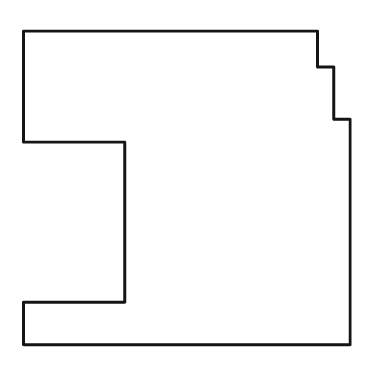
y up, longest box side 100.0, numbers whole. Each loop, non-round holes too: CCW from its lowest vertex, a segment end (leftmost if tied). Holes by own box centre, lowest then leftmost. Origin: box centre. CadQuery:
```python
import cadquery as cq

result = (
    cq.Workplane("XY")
    .moveTo(-50.0, -48.0)
    .lineTo(50.0, -48.0)
    .lineTo(50.0, 21.0)
    .lineTo(45.0, 21.0)
    .lineTo(45.0, 37.0)
    .lineTo(40.0, 37.0)
    .lineTo(40.0, 48.0)
    .lineTo(-50.0, 48.0)
    .lineTo(-50.0, 14.0)
    .lineTo(-19.0, 14.0)
    .lineTo(-19.0, -35.0)
    .lineTo(-50.0, -35.0)
    .close()
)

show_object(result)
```